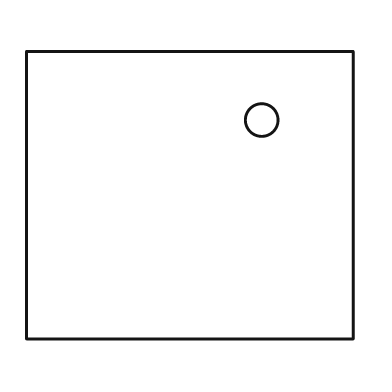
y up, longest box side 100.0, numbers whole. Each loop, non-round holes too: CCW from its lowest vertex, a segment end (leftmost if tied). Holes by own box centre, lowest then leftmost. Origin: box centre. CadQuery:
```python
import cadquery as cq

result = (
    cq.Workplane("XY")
    .moveTo(-50.0, -44.0)
    .lineTo(50.0, -44.0)
    .lineTo(50.0, 44.0)
    .lineTo(-50.0, 44.0)
    .close()
    .moveTo(22.0, 23.0)
    .circle(5.0)
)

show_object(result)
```